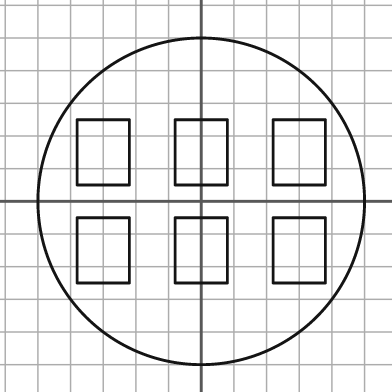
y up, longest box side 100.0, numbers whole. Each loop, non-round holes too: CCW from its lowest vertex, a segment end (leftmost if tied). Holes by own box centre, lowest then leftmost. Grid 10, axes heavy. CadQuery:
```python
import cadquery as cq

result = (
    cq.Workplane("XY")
    .moveTo(0.0, 0.0)
    .circle(50.0)
    .moveTo(-38.0, -25.0)
    .lineTo(-22.0, -25.0)
    .lineTo(-22.0, -5.0)
    .lineTo(-38.0, -5.0)
    .close()
    .moveTo(-8.0, -25.0)
    .lineTo(8.0, -25.0)
    .lineTo(8.0, -5.0)
    .lineTo(-8.0, -5.0)
    .close()
    .moveTo(22.0, -25.0)
    .lineTo(38.0, -25.0)
    .lineTo(38.0, -5.0)
    .lineTo(22.0, -5.0)
    .close()
    .moveTo(-38.0, 5.0)
    .lineTo(-22.0, 5.0)
    .lineTo(-22.0, 25.0)
    .lineTo(-38.0, 25.0)
    .close()
    .moveTo(-8.0, 5.0)
    .lineTo(8.0, 5.0)
    .lineTo(8.0, 25.0)
    .lineTo(-8.0, 25.0)
    .close()
    .moveTo(22.0, 5.0)
    .lineTo(38.0, 5.0)
    .lineTo(38.0, 25.0)
    .lineTo(22.0, 25.0)
    .close()
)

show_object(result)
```